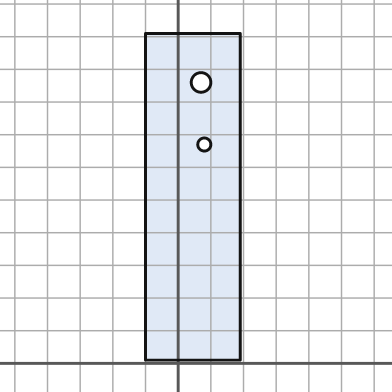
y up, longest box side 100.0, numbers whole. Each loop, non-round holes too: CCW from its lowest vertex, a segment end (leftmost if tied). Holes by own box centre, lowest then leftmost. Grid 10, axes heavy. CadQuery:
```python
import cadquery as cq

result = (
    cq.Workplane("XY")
    .moveTo(-10.0, 1.0)
    .lineTo(19.0, 1.0)
    .lineTo(19.0, 101.0)
    .lineTo(-10.0, 101.0)
    .close()
    .moveTo(8.0, 67.0)
    .circle(2.0)
    .moveTo(7.0, 86.0)
    .circle(3.0)
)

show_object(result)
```